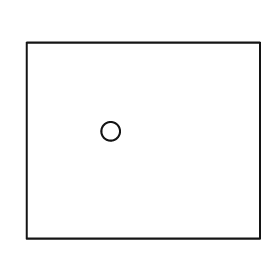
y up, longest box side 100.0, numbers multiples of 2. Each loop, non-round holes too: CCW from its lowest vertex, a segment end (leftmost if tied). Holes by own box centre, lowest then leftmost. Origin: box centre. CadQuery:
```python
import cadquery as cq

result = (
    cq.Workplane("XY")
    .moveTo(-50.0, -42.0)
    .lineTo(50.0, -42.0)
    .lineTo(50.0, 42.0)
    .lineTo(-50.0, 42.0)
    .close()
    .moveTo(-14.0, 4.0)
    .circle(4.0)
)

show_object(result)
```